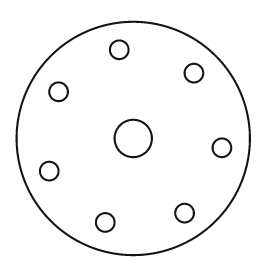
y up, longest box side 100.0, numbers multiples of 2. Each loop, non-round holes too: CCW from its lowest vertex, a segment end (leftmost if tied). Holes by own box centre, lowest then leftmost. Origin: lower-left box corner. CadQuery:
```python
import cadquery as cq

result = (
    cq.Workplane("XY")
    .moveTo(50.0, 50.0)
    .circle(50.0)
    .moveTo(38.0, 14.0)
    .circle(4.0)
    .moveTo(72.0, 18.0)
    .circle(4.0)
    .moveTo(14.0, 36.0)
    .circle(4.0)
    .moveTo(88.0, 46.0)
    .circle(4.0)
    .moveTo(50.0, 50.0)
    .circle(8.0)
    .moveTo(18.0, 70.0)
    .circle(4.0)
    .moveTo(76.0, 78.0)
    .circle(4.0)
    .moveTo(44.0, 88.0)
    .circle(4.0)
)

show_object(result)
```